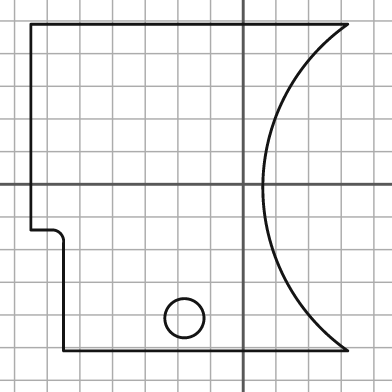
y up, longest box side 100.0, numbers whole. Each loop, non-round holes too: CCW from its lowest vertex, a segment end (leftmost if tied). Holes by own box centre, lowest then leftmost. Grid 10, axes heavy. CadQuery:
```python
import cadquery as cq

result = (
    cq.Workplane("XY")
    .moveTo(-55.0, -51.0)
    .lineTo(32.0, -51.0)
    .threePointArc((6.0, -1.0), (32.0, 49.0))
    .lineTo(-65.0, 49.0)
    .lineTo(-65.0, -14.0)
    .lineTo(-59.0, -14.0)
    .threePointArc((-56.0, -15.0), (-55.0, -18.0))
    .close()
    .moveTo(-18.0, -41.0)
    .circle(6.0)
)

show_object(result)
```